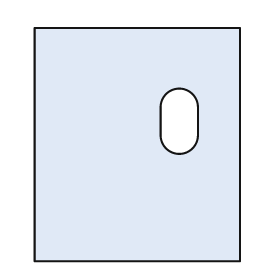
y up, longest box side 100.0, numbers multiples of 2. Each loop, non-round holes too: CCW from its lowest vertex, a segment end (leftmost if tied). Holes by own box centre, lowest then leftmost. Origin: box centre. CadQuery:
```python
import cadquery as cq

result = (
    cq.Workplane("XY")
    .moveTo(-44.0, -50.0)
    .lineTo(44.0, -50.0)
    .lineTo(44.0, 50.0)
    .lineTo(-44.0, 50.0)
    .close()
    .moveTo(10.0, 4.0)
    .threePointArc((18.0, -4.0), (26.0, 4.0))
    .lineTo(26.0, 16.0)
    .threePointArc((18.0, 24.0), (10.0, 16.0))
    .close()
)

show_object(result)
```